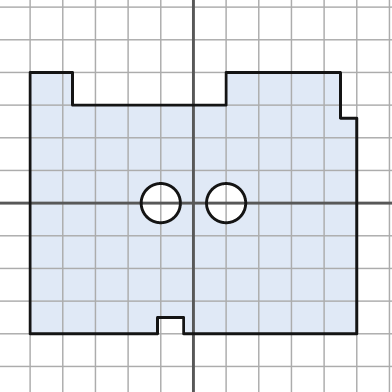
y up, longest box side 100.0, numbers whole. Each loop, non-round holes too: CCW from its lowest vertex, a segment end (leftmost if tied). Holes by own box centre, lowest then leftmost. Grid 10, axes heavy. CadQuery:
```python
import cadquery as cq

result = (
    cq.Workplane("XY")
    .moveTo(-50.0, -40.0)
    .lineTo(-11.0, -40.0)
    .lineTo(-11.0, -35.0)
    .lineTo(-3.0, -35.0)
    .lineTo(-3.0, -40.0)
    .lineTo(50.0, -40.0)
    .lineTo(50.0, 26.0)
    .lineTo(45.0, 26.0)
    .lineTo(45.0, 40.0)
    .lineTo(10.0, 40.0)
    .lineTo(10.0, 30.0)
    .lineTo(-37.0, 30.0)
    .lineTo(-37.0, 40.0)
    .lineTo(-50.0, 40.0)
    .close()
    .moveTo(-10.0, 0.0)
    .circle(6.0)
    .moveTo(10.0, 0.0)
    .circle(6.0)
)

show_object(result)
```